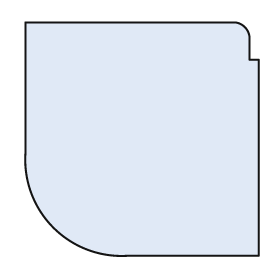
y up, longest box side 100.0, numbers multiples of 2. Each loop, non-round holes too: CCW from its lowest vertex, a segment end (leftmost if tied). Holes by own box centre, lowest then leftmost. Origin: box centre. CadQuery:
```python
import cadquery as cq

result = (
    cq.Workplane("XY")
    .moveTo(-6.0, -50.0)
    .lineTo(50.0, -50.0)
    .lineTo(50.0, 34.0)
    .lineTo(46.0, 34.0)
    .lineTo(46.0, 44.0)
    .threePointArc((44.0, 48.0), (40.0, 50.0))
    .lineTo(-50.0, 50.0)
    .lineTo(-50.0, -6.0)
    .threePointArc((-38.0, -38.0), (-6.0, -50.0))
    .close()
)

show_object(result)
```